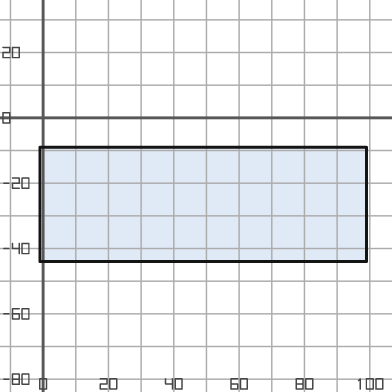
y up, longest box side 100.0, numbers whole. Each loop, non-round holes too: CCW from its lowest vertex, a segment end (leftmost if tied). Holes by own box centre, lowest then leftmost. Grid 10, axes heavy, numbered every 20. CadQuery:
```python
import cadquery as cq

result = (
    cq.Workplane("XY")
    .moveTo(-1.0, -44.0)
    .lineTo(99.0, -44.0)
    .lineTo(99.0, -9.0)
    .lineTo(-1.0, -9.0)
    .close()
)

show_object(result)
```